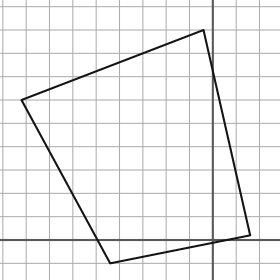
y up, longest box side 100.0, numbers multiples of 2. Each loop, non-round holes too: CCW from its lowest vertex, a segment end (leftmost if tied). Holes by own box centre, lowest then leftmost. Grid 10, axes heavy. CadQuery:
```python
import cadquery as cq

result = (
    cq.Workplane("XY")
    .moveTo(-44.0, -10.0)
    .lineTo(16.0, 2.0)
    .lineTo(-4.0, 90.0)
    .lineTo(-82.0, 60.0)
    .close()
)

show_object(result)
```